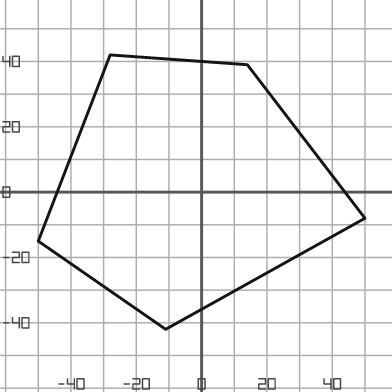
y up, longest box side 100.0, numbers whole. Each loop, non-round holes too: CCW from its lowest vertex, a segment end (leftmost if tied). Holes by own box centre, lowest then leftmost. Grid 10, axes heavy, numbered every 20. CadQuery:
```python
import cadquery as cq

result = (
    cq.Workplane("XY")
    .moveTo(-11.0, -42.0)
    .lineTo(50.0, -8.0)
    .lineTo(14.0, 39.0)
    .lineTo(-28.0, 42.0)
    .lineTo(-50.0, -15.0)
    .close()
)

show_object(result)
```